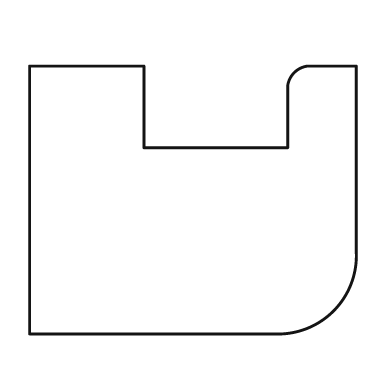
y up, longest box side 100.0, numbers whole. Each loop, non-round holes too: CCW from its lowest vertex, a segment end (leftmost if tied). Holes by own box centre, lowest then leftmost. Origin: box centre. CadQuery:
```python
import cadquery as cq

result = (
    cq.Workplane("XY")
    .moveTo(-50.0, -41.0)
    .lineTo(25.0, -41.0)
    .threePointArc((43.0, -34.0), (50.0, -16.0))
    .lineTo(50.0, 41.0)
    .lineTo(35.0, 41.0)
    .threePointArc((31.0, 39.0), (29.0, 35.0))
    .lineTo(29.0, 16.0)
    .lineTo(-15.0, 16.0)
    .lineTo(-15.0, 41.0)
    .lineTo(-50.0, 41.0)
    .close()
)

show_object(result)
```